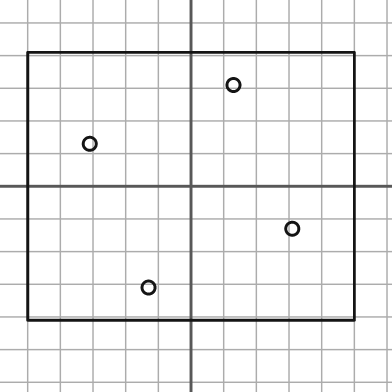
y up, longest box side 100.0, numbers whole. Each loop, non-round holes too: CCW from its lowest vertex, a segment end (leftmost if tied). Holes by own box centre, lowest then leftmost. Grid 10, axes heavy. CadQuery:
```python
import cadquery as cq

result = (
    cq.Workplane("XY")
    .moveTo(-50.0, -41.0)
    .lineTo(50.0, -41.0)
    .lineTo(50.0, 41.0)
    .lineTo(-50.0, 41.0)
    .close()
    .moveTo(-13.0, -31.0)
    .circle(2.0)
    .moveTo(31.0, -13.0)
    .circle(2.0)
    .moveTo(-31.0, 13.0)
    .circle(2.0)
    .moveTo(13.0, 31.0)
    .circle(2.0)
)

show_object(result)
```